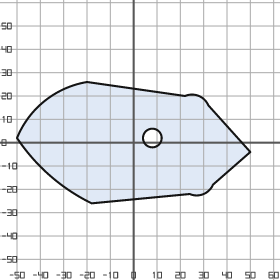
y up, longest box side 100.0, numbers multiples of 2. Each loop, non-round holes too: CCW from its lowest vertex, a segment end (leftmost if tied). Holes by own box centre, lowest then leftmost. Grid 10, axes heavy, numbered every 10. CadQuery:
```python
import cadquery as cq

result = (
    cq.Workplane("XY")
    .moveTo(-18.0, -26.0)
    .lineTo(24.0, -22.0)
    .threePointArc((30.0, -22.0), (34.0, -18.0))
    .lineTo(50.0, -4.0)
    .lineTo(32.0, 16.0)
    .threePointArc((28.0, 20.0), (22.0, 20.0))
    .lineTo(-20.0, 26.0)
    .threePointArc((-38.0, 18.0), (-50.0, 2.0))
    .threePointArc((-36.0, -14.0), (-18.0, -26.0))
    .close()
    .moveTo(8.0, 2.0)
    .circle(4.0)
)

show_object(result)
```